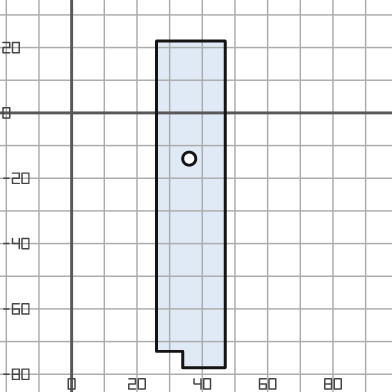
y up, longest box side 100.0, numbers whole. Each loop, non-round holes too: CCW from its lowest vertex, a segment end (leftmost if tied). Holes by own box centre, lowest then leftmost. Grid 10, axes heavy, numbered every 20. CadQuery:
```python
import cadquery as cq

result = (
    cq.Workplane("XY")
    .moveTo(34.0, -78.0)
    .lineTo(47.0, -78.0)
    .lineTo(47.0, 22.0)
    .lineTo(26.0, 22.0)
    .lineTo(26.0, -73.0)
    .lineTo(34.0, -73.0)
    .close()
    .moveTo(36.0, -14.0)
    .circle(2.0)
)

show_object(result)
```